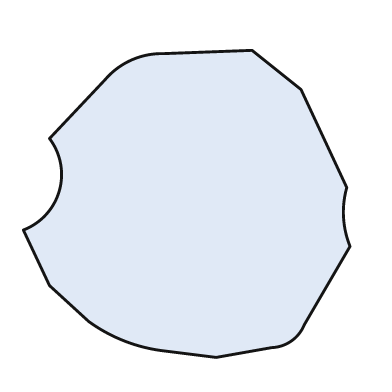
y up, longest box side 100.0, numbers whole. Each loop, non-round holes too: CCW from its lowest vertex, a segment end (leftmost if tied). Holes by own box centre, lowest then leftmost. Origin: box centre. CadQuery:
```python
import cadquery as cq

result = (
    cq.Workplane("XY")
    .moveTo(9.0, -47.0)
    .lineTo(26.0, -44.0)
    .threePointArc((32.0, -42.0), (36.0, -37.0))
    .lineTo(50.0, -13.0)
    .threePointArc((48.0, -4.0), (49.0, 5.0))
    .lineTo(35.0, 35.0)
    .lineTo(20.0, 47.0)
    .lineTo(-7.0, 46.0)
    .threePointArc((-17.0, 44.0), (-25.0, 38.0))
    .lineTo(-42.0, 20.0)
    .threePointArc((-39.0, 4.0), (-50.0, -8.0))
    .lineTo(-42.0, -25.0)
    .lineTo(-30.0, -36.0)
    .threePointArc((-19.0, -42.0), (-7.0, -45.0))
    .close()
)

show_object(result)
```